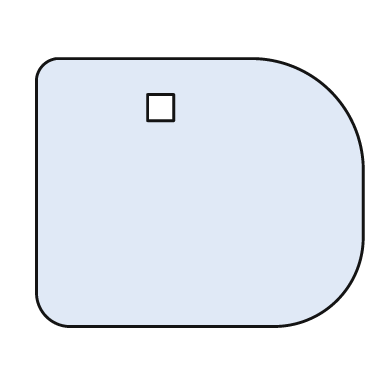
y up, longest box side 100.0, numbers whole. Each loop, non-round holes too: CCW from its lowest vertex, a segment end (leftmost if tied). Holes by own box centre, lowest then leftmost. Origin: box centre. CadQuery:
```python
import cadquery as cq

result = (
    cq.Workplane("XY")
    .moveTo(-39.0, -41.0)
    .lineTo(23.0, -41.0)
    .threePointArc((42.0, -33.0), (50.0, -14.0))
    .lineTo(50.0, 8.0)
    .threePointArc((40.0, 31.0), (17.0, 41.0))
    .lineTo(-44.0, 41.0)
    .threePointArc((-48.0, 39.0), (-50.0, 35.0))
    .lineTo(-50.0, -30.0)
    .threePointArc((-47.0, -38.0), (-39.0, -41.0))
    .close()
    .moveTo(-16.0, 22.0)
    .lineTo(-8.0, 22.0)
    .lineTo(-8.0, 30.0)
    .lineTo(-16.0, 30.0)
    .close()
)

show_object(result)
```